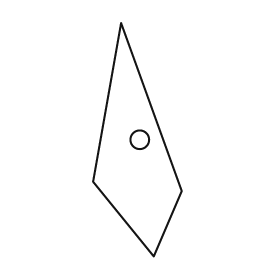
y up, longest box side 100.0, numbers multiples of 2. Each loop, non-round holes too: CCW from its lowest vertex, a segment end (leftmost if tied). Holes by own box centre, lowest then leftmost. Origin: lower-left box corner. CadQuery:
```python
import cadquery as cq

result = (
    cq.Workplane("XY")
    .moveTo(26.0, 0.0)
    .lineTo(38.0, 28.0)
    .lineTo(12.0, 100.0)
    .lineTo(0.0, 32.0)
    .close()
    .moveTo(20.0, 50.0)
    .circle(4.0)
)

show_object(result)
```